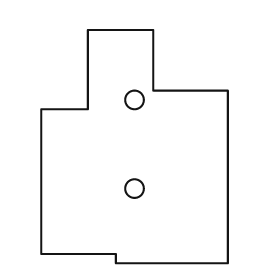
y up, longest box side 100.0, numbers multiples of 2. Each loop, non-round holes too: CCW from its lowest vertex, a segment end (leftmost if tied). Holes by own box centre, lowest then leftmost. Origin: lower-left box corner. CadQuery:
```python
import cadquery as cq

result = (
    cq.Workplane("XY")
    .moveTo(32.0, 0.0)
    .lineTo(80.0, 0.0)
    .lineTo(80.0, 74.0)
    .lineTo(48.0, 74.0)
    .lineTo(48.0, 100.0)
    .lineTo(20.0, 100.0)
    .lineTo(20.0, 66.0)
    .lineTo(0.0, 66.0)
    .lineTo(0.0, 4.0)
    .lineTo(32.0, 4.0)
    .close()
    .moveTo(40.0, 32.0)
    .circle(4.0)
    .moveTo(40.0, 70.0)
    .circle(4.0)
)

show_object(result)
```